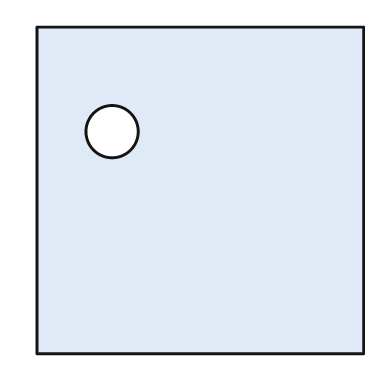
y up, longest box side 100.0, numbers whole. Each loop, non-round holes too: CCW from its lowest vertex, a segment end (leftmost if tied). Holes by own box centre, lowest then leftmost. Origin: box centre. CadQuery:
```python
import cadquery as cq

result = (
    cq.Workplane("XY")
    .moveTo(-50.0, -50.0)
    .lineTo(50.0, -50.0)
    .lineTo(50.0, 50.0)
    .lineTo(-50.0, 50.0)
    .close()
    .moveTo(-27.0, 18.0)
    .circle(8.0)
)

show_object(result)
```